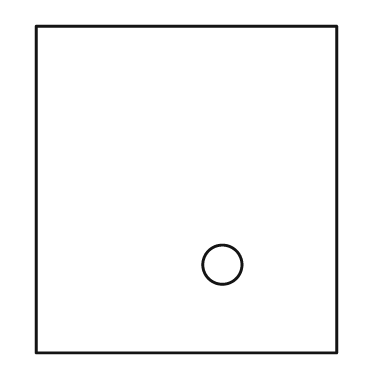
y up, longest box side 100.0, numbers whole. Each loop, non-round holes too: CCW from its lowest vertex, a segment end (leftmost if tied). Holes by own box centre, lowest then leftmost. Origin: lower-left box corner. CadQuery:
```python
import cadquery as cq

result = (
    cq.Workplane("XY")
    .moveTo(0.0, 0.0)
    .lineTo(92.0, 0.0)
    .lineTo(92.0, 100.0)
    .lineTo(0.0, 100.0)
    .close()
    .moveTo(57.0, 27.0)
    .circle(6.0)
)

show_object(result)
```